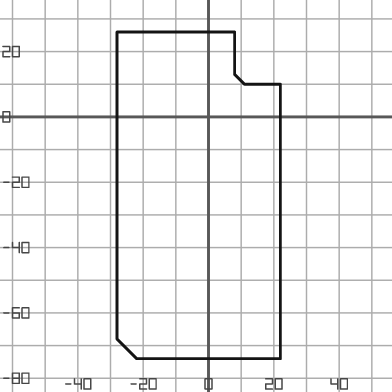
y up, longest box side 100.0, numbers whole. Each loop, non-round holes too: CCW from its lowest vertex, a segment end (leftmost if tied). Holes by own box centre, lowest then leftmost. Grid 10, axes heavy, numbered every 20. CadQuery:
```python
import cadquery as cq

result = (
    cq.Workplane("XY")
    .moveTo(-22.0, -74.0)
    .lineTo(22.0, -74.0)
    .lineTo(22.0, 10.0)
    .lineTo(11.0, 10.0)
    .lineTo(8.0, 13.0)
    .lineTo(8.0, 26.0)
    .lineTo(-28.0, 26.0)
    .lineTo(-28.0, -68.0)
    .close()
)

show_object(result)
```